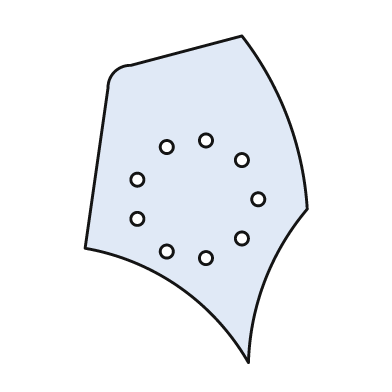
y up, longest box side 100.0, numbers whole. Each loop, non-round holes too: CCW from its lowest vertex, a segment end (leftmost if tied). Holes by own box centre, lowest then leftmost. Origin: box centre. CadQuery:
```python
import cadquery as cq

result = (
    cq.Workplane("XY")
    .moveTo(16.0, -50.0)
    .threePointArc((21.0, -25.0), (34.0, -3.0))
    .threePointArc((28.0, 25.0), (14.0, 50.0))
    .lineTo(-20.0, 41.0)
    .threePointArc((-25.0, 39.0), (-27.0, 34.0))
    .lineTo(-34.0, -15.0)
    .threePointArc((-5.0, -27.0), (16.0, -50.0))
    .close()
    .moveTo(3.0, -18.0)
    .circle(2.0)
    .moveTo(-9.0, -16.0)
    .circle(2.0)
    .moveTo(14.0, -12.0)
    .circle(2.0)
    .moveTo(-18.0, -6.0)
    .circle(2.0)
    .moveTo(19.0, 0.0)
    .circle(2.0)
    .moveTo(-18.0, 6.0)
    .circle(2.0)
    .moveTo(14.0, 12.0)
    .circle(2.0)
    .moveTo(-9.0, 16.0)
    .circle(2.0)
    .moveTo(3.0, 18.0)
    .circle(2.0)
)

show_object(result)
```